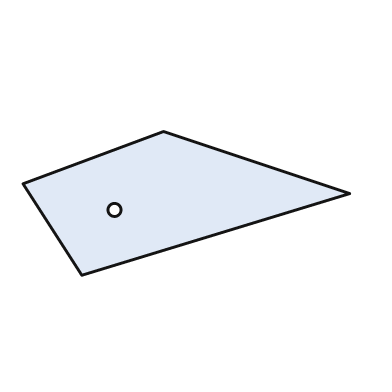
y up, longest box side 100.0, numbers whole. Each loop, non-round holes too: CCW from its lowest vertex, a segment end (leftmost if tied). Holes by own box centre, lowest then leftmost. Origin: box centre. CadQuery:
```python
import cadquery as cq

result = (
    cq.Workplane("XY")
    .moveTo(-32.0, -22.0)
    .lineTo(50.0, 3.0)
    .lineTo(-7.0, 22.0)
    .lineTo(-50.0, 6.0)
    .close()
    .moveTo(-22.0, -2.0)
    .circle(2.0)
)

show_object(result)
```